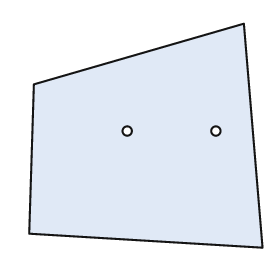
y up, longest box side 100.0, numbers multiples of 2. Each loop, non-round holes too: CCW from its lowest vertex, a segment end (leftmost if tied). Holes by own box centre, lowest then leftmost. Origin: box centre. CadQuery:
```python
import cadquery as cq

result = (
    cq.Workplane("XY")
    .moveTo(50.0, -48.0)
    .lineTo(42.0, 48.0)
    .lineTo(-48.0, 22.0)
    .lineTo(-50.0, -42.0)
    .close()
    .moveTo(-8.0, 2.0)
    .circle(2.0)
    .moveTo(30.0, 2.0)
    .circle(2.0)
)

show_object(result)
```